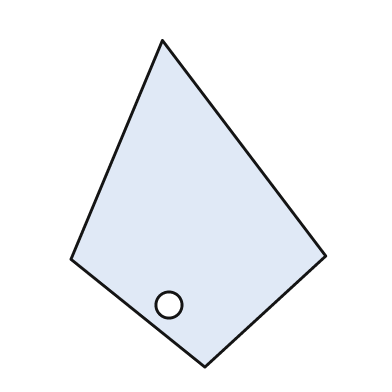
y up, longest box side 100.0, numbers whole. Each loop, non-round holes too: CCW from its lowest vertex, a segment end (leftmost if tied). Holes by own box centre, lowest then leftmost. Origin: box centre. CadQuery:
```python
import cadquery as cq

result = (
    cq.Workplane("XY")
    .moveTo(2.0, -50.0)
    .lineTo(39.0, -16.0)
    .lineTo(-11.0, 50.0)
    .lineTo(-39.0, -17.0)
    .close()
    .moveTo(-9.0, -31.0)
    .circle(4.0)
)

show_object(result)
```